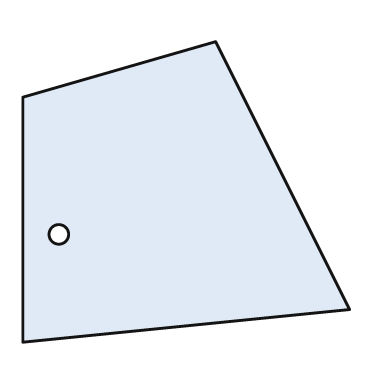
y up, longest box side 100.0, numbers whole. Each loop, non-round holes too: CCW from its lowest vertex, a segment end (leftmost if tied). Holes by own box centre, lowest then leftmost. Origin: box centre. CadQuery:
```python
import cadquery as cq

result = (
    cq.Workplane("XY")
    .moveTo(-50.0, -46.0)
    .lineTo(50.0, -36.0)
    .lineTo(9.0, 46.0)
    .lineTo(-50.0, 29.0)
    .close()
    .moveTo(-39.0, -13.0)
    .circle(3.0)
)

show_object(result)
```